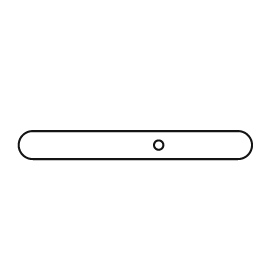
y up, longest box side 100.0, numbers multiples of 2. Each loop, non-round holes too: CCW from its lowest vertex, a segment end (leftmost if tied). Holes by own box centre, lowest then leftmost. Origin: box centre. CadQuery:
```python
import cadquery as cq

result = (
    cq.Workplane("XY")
    .moveTo(-44.0, -6.0)
    .lineTo(44.0, -6.0)
    .threePointArc((50.0, 0.0), (44.0, 6.0))
    .lineTo(-44.0, 6.0)
    .threePointArc((-50.0, 0.0), (-44.0, -6.0))
    .close()
    .moveTo(10.0, 0.0)
    .circle(2.0)
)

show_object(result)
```